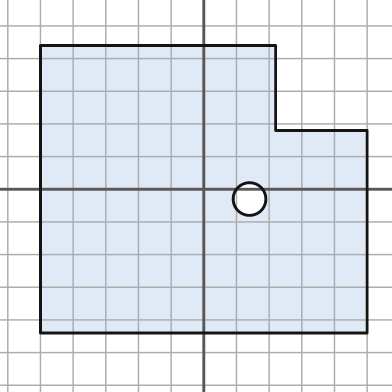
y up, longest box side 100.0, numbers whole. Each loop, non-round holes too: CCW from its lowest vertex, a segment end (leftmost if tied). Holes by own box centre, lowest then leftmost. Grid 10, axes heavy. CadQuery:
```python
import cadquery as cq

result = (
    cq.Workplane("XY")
    .moveTo(-50.0, -44.0)
    .lineTo(50.0, -44.0)
    .lineTo(50.0, 18.0)
    .lineTo(22.0, 18.0)
    .lineTo(22.0, 44.0)
    .lineTo(-50.0, 44.0)
    .close()
    .moveTo(14.0, -3.0)
    .circle(5.0)
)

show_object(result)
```